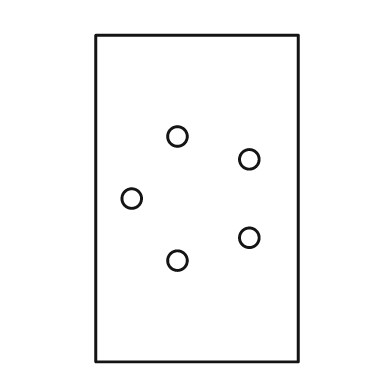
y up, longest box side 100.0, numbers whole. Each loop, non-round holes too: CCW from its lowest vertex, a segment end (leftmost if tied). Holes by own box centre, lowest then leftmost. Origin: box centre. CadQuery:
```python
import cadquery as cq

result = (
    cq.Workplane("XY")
    .moveTo(-31.0, -50.0)
    .lineTo(31.0, -50.0)
    .lineTo(31.0, 50.0)
    .lineTo(-31.0, 50.0)
    .close()
    .moveTo(-6.0, -19.0)
    .circle(3.0)
    .moveTo(16.0, -12.0)
    .circle(3.0)
    .moveTo(-20.0, 0.0)
    .circle(3.0)
    .moveTo(16.0, 12.0)
    .circle(3.0)
    .moveTo(-6.0, 19.0)
    .circle(3.0)
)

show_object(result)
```